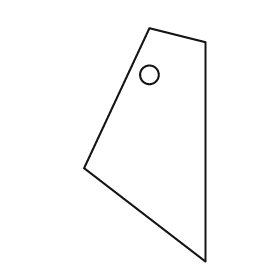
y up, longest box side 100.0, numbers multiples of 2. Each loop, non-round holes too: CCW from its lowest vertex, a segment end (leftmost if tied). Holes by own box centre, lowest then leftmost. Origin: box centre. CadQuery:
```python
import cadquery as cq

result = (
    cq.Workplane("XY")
    .moveTo(26.0, -50.0)
    .lineTo(26.0, 44.0)
    .lineTo(2.0, 50.0)
    .lineTo(-26.0, -10.0)
    .close()
    .moveTo(2.0, 30.0)
    .circle(4.0)
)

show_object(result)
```